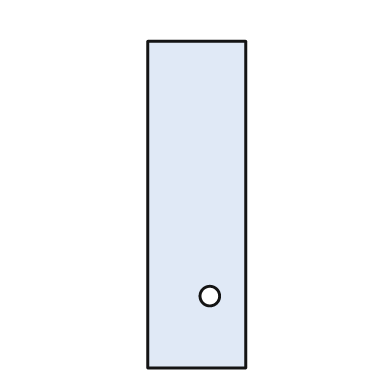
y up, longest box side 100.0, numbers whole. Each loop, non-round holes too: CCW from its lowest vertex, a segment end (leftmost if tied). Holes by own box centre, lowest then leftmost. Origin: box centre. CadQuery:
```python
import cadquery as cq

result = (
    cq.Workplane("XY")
    .moveTo(-15.0, -50.0)
    .lineTo(15.0, -50.0)
    .lineTo(15.0, 50.0)
    .lineTo(-15.0, 50.0)
    .close()
    .moveTo(4.0, -28.0)
    .circle(3.0)
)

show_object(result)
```